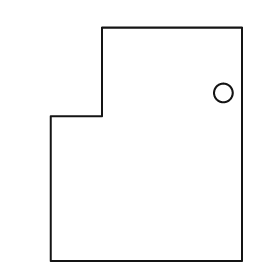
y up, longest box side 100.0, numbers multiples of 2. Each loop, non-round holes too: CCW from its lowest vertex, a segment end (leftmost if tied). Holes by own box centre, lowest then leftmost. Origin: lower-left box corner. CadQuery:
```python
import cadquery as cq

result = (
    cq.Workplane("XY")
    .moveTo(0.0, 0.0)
    .lineTo(82.0, 0.0)
    .lineTo(82.0, 100.0)
    .lineTo(22.0, 100.0)
    .lineTo(22.0, 62.0)
    .lineTo(0.0, 62.0)
    .close()
    .moveTo(74.0, 72.0)
    .circle(4.0)
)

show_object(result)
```